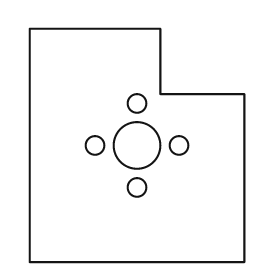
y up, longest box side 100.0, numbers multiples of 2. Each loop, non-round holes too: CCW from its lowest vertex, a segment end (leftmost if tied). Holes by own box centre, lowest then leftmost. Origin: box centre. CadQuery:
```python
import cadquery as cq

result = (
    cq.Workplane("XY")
    .moveTo(-46.0, -50.0)
    .lineTo(46.0, -50.0)
    .lineTo(46.0, 22.0)
    .lineTo(10.0, 22.0)
    .lineTo(10.0, 50.0)
    .lineTo(-46.0, 50.0)
    .close()
    .moveTo(0.0, -18.0)
    .circle(4.0)
    .moveTo(-18.0, 0.0)
    .circle(4.0)
    .moveTo(0.0, 0.0)
    .circle(10.0)
    .moveTo(18.0, 0.0)
    .circle(4.0)
    .moveTo(0.0, 18.0)
    .circle(4.0)
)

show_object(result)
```